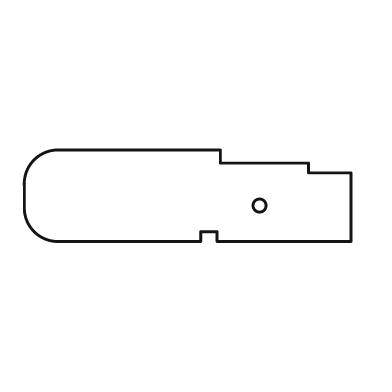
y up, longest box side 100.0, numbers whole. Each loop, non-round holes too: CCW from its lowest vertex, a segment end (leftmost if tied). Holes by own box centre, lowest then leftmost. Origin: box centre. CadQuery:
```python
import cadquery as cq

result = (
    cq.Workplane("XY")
    .moveTo(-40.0, -14.0)
    .lineTo(4.0, -14.0)
    .lineTo(4.0, -11.0)
    .lineTo(9.0, -11.0)
    .lineTo(9.0, -14.0)
    .lineTo(50.0, -14.0)
    .lineTo(50.0, 7.0)
    .lineTo(37.0, 7.0)
    .lineTo(37.0, 10.0)
    .lineTo(10.0, 10.0)
    .lineTo(10.0, 14.0)
    .lineTo(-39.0, 14.0)
    .threePointArc((-47.0, 11.0), (-50.0, 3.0))
    .lineTo(-50.0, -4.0)
    .threePointArc((-47.0, -11.0), (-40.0, -14.0))
    .close()
    .moveTo(22.0, -3.0)
    .circle(2.0)
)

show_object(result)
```